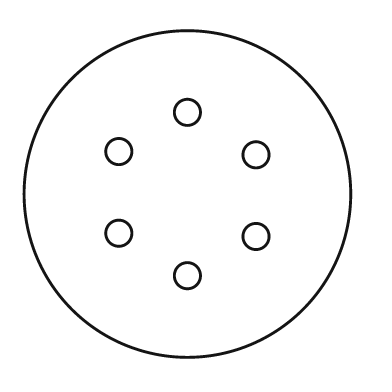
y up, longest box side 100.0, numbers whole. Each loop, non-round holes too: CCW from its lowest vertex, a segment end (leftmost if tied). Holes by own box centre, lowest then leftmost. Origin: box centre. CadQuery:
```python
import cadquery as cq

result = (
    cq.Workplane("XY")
    .moveTo(0.0, 0.0)
    .circle(50.0)
    .moveTo(0.0, -25.0)
    .circle(4.0)
    .moveTo(21.0, -13.0)
    .circle(4.0)
    .moveTo(-21.0, -12.0)
    .circle(4.0)
    .moveTo(21.0, 12.0)
    .circle(4.0)
    .moveTo(-21.0, 13.0)
    .circle(4.0)
    .moveTo(0.0, 25.0)
    .circle(4.0)
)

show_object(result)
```